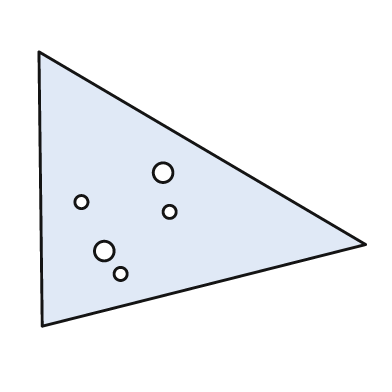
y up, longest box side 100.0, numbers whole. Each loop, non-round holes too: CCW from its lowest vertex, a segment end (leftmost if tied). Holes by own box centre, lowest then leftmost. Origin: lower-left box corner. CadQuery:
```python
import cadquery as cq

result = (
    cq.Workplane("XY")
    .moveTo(1.0, 0.0)
    .lineTo(100.0, 25.0)
    .lineTo(0.0, 84.0)
    .close()
    .moveTo(25.0, 16.0)
    .circle(2.0)
    .moveTo(20.0, 23.0)
    .circle(3.0)
    .moveTo(40.0, 35.0)
    .circle(2.0)
    .moveTo(13.0, 38.0)
    .circle(2.0)
    .moveTo(38.0, 47.0)
    .circle(3.0)
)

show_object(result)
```